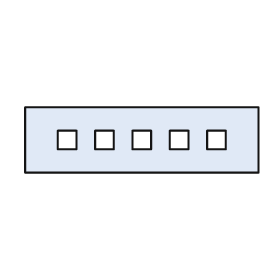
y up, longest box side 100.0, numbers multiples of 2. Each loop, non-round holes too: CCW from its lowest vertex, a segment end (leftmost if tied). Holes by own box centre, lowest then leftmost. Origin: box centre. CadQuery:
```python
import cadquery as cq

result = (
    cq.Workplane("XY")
    .moveTo(-50.0, -14.0)
    .lineTo(50.0, -14.0)
    .lineTo(50.0, 14.0)
    .lineTo(-50.0, 14.0)
    .close()
    .moveTo(-36.0, -4.0)
    .lineTo(-28.0, -4.0)
    .lineTo(-28.0, 4.0)
    .lineTo(-36.0, 4.0)
    .close()
    .moveTo(-20.0, -4.0)
    .lineTo(-12.0, -4.0)
    .lineTo(-12.0, 4.0)
    .lineTo(-20.0, 4.0)
    .close()
    .moveTo(-4.0, -4.0)
    .lineTo(4.0, -4.0)
    .lineTo(4.0, 4.0)
    .lineTo(-4.0, 4.0)
    .close()
    .moveTo(12.0, -4.0)
    .lineTo(20.0, -4.0)
    .lineTo(20.0, 4.0)
    .lineTo(12.0, 4.0)
    .close()
    .moveTo(28.0, -4.0)
    .lineTo(36.0, -4.0)
    .lineTo(36.0, 4.0)
    .lineTo(28.0, 4.0)
    .close()
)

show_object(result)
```